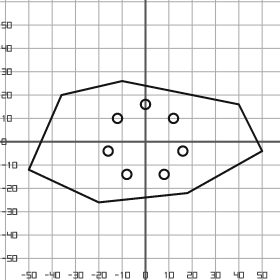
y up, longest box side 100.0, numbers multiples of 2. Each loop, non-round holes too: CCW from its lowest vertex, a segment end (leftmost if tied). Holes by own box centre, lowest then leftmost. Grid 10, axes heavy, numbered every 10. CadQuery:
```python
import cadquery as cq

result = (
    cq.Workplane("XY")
    .moveTo(-20.0, -26.0)
    .lineTo(18.0, -22.0)
    .lineTo(50.0, -4.0)
    .lineTo(40.0, 16.0)
    .lineTo(-10.0, 26.0)
    .lineTo(-36.0, 20.0)
    .lineTo(-50.0, -12.0)
    .close()
    .moveTo(-8.0, -14.0)
    .circle(2.0)
    .moveTo(8.0, -14.0)
    .circle(2.0)
    .moveTo(-16.0, -4.0)
    .circle(2.0)
    .moveTo(16.0, -4.0)
    .circle(2.0)
    .moveTo(-12.0, 10.0)
    .circle(2.0)
    .moveTo(12.0, 10.0)
    .circle(2.0)
    .moveTo(0.0, 16.0)
    .circle(2.0)
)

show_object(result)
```